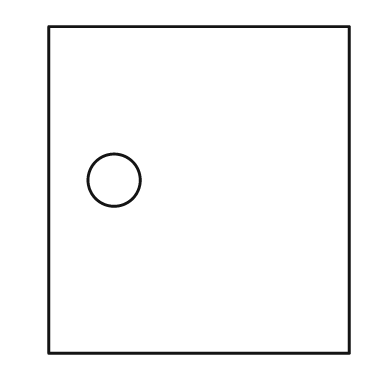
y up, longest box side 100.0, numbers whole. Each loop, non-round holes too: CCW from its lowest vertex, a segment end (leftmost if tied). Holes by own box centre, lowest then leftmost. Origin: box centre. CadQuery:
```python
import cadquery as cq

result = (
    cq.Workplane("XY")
    .moveTo(-46.0, -50.0)
    .lineTo(46.0, -50.0)
    .lineTo(46.0, 50.0)
    .lineTo(-46.0, 50.0)
    .close()
    .moveTo(-26.0, 3.0)
    .circle(8.0)
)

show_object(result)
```